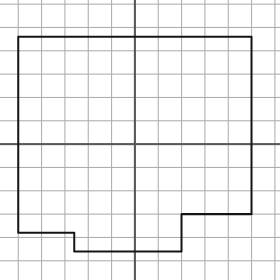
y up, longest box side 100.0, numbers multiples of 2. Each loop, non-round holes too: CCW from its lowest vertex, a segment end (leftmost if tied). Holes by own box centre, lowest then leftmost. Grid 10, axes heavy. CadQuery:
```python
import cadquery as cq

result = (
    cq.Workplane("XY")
    .moveTo(-26.0, -46.0)
    .lineTo(20.0, -46.0)
    .lineTo(20.0, -30.0)
    .lineTo(50.0, -30.0)
    .lineTo(50.0, 46.0)
    .lineTo(-50.0, 46.0)
    .lineTo(-50.0, -38.0)
    .lineTo(-26.0, -38.0)
    .close()
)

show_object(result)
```